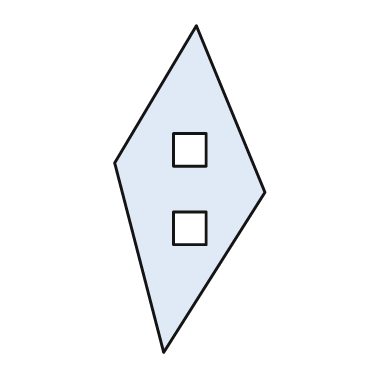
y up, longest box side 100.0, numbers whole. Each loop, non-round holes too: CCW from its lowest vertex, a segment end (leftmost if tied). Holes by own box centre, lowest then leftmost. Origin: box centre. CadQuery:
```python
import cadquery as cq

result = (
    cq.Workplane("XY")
    .moveTo(-8.0, -50.0)
    .lineTo(23.0, -1.0)
    .lineTo(2.0, 50.0)
    .lineTo(-23.0, 8.0)
    .close()
    .moveTo(-5.0, -17.0)
    .lineTo(5.0, -17.0)
    .lineTo(5.0, -7.0)
    .lineTo(-5.0, -7.0)
    .close()
    .moveTo(-5.0, 7.0)
    .lineTo(5.0, 7.0)
    .lineTo(5.0, 17.0)
    .lineTo(-5.0, 17.0)
    .close()
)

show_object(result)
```